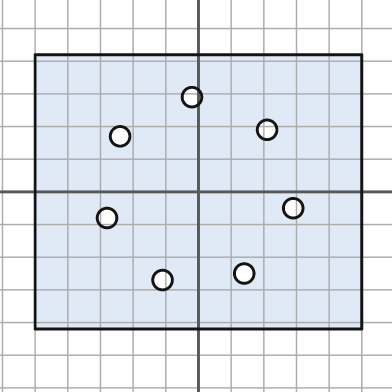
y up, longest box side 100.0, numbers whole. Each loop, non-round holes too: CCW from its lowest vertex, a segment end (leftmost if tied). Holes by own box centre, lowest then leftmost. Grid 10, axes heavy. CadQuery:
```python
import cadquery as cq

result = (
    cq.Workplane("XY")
    .moveTo(-50.0, -42.0)
    .lineTo(50.0, -42.0)
    .lineTo(50.0, 42.0)
    .lineTo(-50.0, 42.0)
    .close()
    .moveTo(-11.0, -27.0)
    .circle(3.0)
    .moveTo(14.0, -25.0)
    .circle(3.0)
    .moveTo(-28.0, -8.0)
    .circle(3.0)
    .moveTo(29.0, -5.0)
    .circle(3.0)
    .moveTo(-24.0, 17.0)
    .circle(3.0)
    .moveTo(21.0, 19.0)
    .circle(3.0)
    .moveTo(-2.0, 29.0)
    .circle(3.0)
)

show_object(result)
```